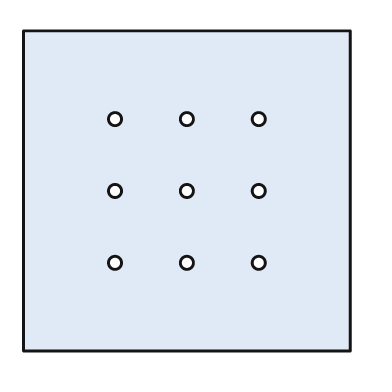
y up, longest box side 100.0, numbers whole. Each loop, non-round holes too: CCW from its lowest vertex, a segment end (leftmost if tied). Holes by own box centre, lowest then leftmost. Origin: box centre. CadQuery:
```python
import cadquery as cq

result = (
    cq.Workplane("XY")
    .moveTo(-50.0, -49.0)
    .lineTo(50.0, -49.0)
    .lineTo(50.0, 49.0)
    .lineTo(-50.0, 49.0)
    .close()
    .moveTo(-22.0, -22.0)
    .circle(2.0)
    .moveTo(0.0, -22.0)
    .circle(2.0)
    .moveTo(22.0, -22.0)
    .circle(2.0)
    .moveTo(-22.0, 0.0)
    .circle(2.0)
    .moveTo(0.0, 0.0)
    .circle(2.0)
    .moveTo(22.0, 0.0)
    .circle(2.0)
    .moveTo(-22.0, 22.0)
    .circle(2.0)
    .moveTo(0.0, 22.0)
    .circle(2.0)
    .moveTo(22.0, 22.0)
    .circle(2.0)
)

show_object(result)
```